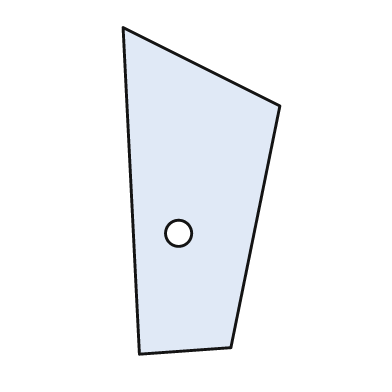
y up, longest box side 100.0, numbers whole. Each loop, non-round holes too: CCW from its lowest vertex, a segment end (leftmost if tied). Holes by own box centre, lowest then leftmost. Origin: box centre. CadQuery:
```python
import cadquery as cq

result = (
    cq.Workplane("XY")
    .moveTo(-19.0, -50.0)
    .lineTo(9.0, -48.0)
    .lineTo(24.0, 26.0)
    .lineTo(-24.0, 50.0)
    .close()
    .moveTo(-7.0, -13.0)
    .circle(4.0)
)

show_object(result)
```